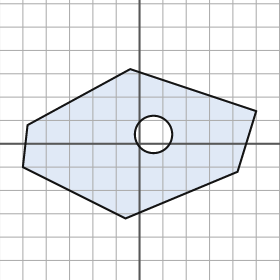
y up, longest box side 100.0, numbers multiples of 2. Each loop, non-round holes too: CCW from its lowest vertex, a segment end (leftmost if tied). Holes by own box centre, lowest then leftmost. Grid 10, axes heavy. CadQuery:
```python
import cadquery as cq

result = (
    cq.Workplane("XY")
    .moveTo(-6.0, -32.0)
    .lineTo(42.0, -12.0)
    .lineTo(50.0, 14.0)
    .lineTo(-4.0, 32.0)
    .lineTo(-48.0, 8.0)
    .lineTo(-50.0, -10.0)
    .close()
    .moveTo(6.0, 4.0)
    .circle(8.0)
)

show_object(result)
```